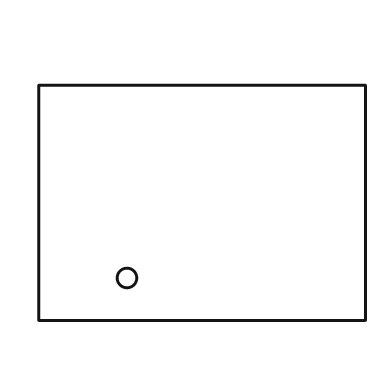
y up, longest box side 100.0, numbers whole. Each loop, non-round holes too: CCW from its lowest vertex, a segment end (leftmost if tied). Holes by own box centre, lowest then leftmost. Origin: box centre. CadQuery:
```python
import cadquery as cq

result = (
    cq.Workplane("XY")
    .moveTo(-50.0, -36.0)
    .lineTo(50.0, -36.0)
    .lineTo(50.0, 36.0)
    .lineTo(-50.0, 36.0)
    .close()
    .moveTo(-23.0, -23.0)
    .circle(3.0)
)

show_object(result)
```